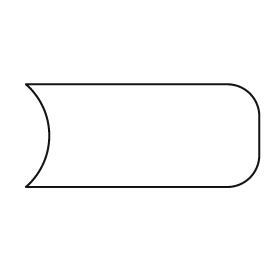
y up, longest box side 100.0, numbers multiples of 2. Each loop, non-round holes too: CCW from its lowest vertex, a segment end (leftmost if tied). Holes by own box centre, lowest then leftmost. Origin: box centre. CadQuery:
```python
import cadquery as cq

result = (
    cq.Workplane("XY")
    .moveTo(-50.0, -22.0)
    .lineTo(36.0, -22.0)
    .threePointArc((46.0, -18.0), (50.0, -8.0))
    .lineTo(50.0, 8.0)
    .threePointArc((46.0, 18.0), (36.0, 22.0))
    .lineTo(-50.0, 22.0)
    .threePointArc((-40.0, 0.0), (-50.0, -22.0))
    .close()
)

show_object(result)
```